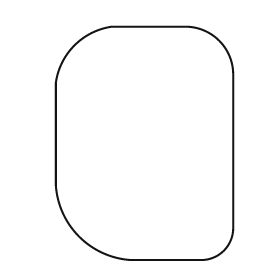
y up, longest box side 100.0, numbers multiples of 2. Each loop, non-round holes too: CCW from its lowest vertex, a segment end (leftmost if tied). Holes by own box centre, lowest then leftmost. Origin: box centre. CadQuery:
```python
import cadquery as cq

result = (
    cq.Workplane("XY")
    .moveTo(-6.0, -50.0)
    .lineTo(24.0, -50.0)
    .threePointArc((34.0, -46.0), (38.0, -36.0))
    .lineTo(38.0, 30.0)
    .threePointArc((32.0, 44.0), (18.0, 50.0))
    .lineTo(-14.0, 50.0)
    .threePointArc((-30.0, 42.0), (-38.0, 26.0))
    .lineTo(-38.0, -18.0)
    .threePointArc((-28.0, -40.0), (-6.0, -50.0))
    .close()
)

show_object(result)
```